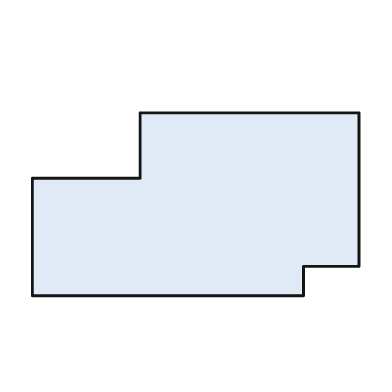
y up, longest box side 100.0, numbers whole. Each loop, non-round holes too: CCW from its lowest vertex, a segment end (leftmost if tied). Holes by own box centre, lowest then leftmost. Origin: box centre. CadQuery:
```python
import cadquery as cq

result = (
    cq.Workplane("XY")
    .moveTo(-50.0, -28.0)
    .lineTo(33.0, -28.0)
    .lineTo(33.0, -19.0)
    .lineTo(50.0, -19.0)
    .lineTo(50.0, 28.0)
    .lineTo(-17.0, 28.0)
    .lineTo(-17.0, 8.0)
    .lineTo(-50.0, 8.0)
    .close()
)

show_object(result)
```